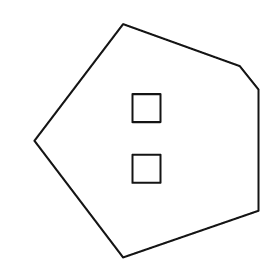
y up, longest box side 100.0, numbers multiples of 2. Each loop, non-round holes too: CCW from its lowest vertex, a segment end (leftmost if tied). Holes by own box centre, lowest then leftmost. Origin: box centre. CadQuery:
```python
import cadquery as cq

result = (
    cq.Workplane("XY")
    .moveTo(-10.0, -50.0)
    .lineTo(48.0, -30.0)
    .lineTo(48.0, 22.0)
    .lineTo(40.0, 32.0)
    .lineTo(-10.0, 50.0)
    .lineTo(-48.0, 0.0)
    .close()
    .moveTo(-6.0, -18.0)
    .lineTo(6.0, -18.0)
    .lineTo(6.0, -6.0)
    .lineTo(-6.0, -6.0)
    .close()
    .moveTo(-6.0, 8.0)
    .lineTo(6.0, 8.0)
    .lineTo(6.0, 20.0)
    .lineTo(-6.0, 20.0)
    .close()
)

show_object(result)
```